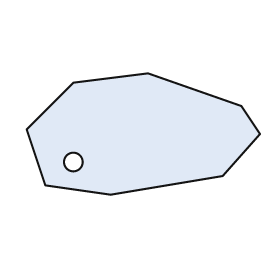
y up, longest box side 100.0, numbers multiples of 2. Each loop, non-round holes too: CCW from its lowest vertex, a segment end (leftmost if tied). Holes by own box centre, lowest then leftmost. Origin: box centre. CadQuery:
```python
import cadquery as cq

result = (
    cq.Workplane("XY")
    .moveTo(-14.0, -26.0)
    .lineTo(34.0, -18.0)
    .lineTo(50.0, 0.0)
    .lineTo(42.0, 12.0)
    .lineTo(2.0, 26.0)
    .lineTo(-30.0, 22.0)
    .lineTo(-50.0, 2.0)
    .lineTo(-42.0, -22.0)
    .close()
    .moveTo(-30.0, -12.0)
    .circle(4.0)
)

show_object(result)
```